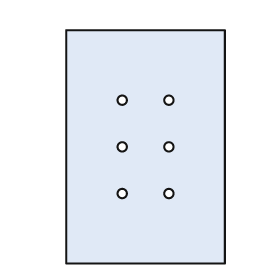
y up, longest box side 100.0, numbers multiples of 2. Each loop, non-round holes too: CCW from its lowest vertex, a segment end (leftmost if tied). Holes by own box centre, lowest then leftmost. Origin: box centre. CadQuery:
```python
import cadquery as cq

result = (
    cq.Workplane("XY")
    .moveTo(-34.0, -50.0)
    .lineTo(34.0, -50.0)
    .lineTo(34.0, 50.0)
    .lineTo(-34.0, 50.0)
    .close()
    .moveTo(-10.0, -20.0)
    .circle(2.0)
    .moveTo(10.0, -20.0)
    .circle(2.0)
    .moveTo(-10.0, 0.0)
    .circle(2.0)
    .moveTo(10.0, 0.0)
    .circle(2.0)
    .moveTo(-10.0, 20.0)
    .circle(2.0)
    .moveTo(10.0, 20.0)
    .circle(2.0)
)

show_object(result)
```